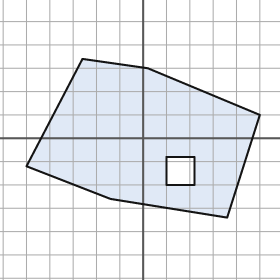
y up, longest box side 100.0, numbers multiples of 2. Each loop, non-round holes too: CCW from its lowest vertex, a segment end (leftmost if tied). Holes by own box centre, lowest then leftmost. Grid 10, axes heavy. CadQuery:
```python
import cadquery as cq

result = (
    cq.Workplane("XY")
    .moveTo(36.0, -34.0)
    .lineTo(50.0, 10.0)
    .lineTo(2.0, 30.0)
    .lineTo(-26.0, 34.0)
    .lineTo(-50.0, -12.0)
    .lineTo(-14.0, -26.0)
    .close()
    .moveTo(10.0, -20.0)
    .lineTo(22.0, -20.0)
    .lineTo(22.0, -8.0)
    .lineTo(10.0, -8.0)
    .close()
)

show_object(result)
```